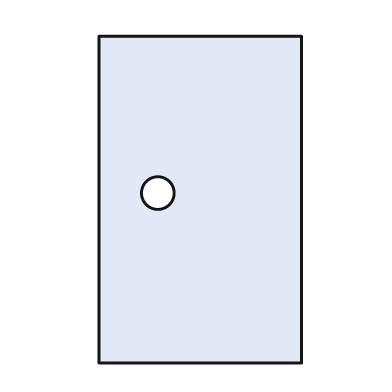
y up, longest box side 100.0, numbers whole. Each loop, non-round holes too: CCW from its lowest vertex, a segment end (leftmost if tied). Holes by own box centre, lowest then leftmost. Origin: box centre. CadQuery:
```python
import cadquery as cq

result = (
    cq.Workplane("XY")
    .moveTo(-31.0, -50.0)
    .lineTo(31.0, -50.0)
    .lineTo(31.0, 50.0)
    .lineTo(-31.0, 50.0)
    .close()
    .moveTo(-13.0, 2.0)
    .circle(5.0)
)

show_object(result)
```